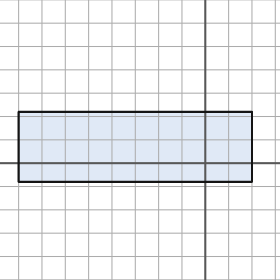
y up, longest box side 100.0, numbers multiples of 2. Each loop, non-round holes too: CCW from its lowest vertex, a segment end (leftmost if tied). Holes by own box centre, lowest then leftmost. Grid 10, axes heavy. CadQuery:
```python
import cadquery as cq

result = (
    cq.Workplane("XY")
    .moveTo(-80.0, -8.0)
    .lineTo(20.0, -8.0)
    .lineTo(20.0, 22.0)
    .lineTo(-80.0, 22.0)
    .close()
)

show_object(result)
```